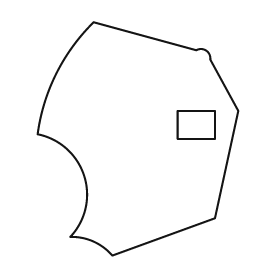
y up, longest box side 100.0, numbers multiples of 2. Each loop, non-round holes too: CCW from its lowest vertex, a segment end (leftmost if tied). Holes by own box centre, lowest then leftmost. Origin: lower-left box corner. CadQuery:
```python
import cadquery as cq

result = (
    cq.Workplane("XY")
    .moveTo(32.0, 0.0)
    .lineTo(76.0, 16.0)
    .lineTo(86.0, 62.0)
    .lineTo(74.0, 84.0)
    .threePointArc((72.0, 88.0), (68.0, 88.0))
    .lineTo(24.0, 100.0)
    .threePointArc((8.0, 78.0), (0.0, 52.0))
    .threePointArc((20.0, 34.0), (14.0, 8.0))
    .threePointArc((24.0, 6.0), (32.0, 0.0))
    .close()
    .moveTo(60.0, 50.0)
    .lineTo(76.0, 50.0)
    .lineTo(76.0, 62.0)
    .lineTo(60.0, 62.0)
    .close()
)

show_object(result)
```